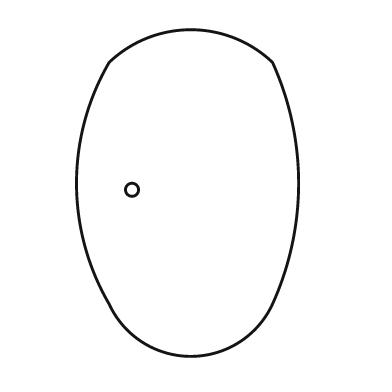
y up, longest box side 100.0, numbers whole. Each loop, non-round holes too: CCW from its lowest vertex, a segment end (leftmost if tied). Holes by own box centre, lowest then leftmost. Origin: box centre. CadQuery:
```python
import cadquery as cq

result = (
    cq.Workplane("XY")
    .moveTo(-24.0, -34.0)
    .threePointArc((1.0, -50.0), (26.0, -34.0))
    .threePointArc((34.0, 3.0), (26.0, 40.0))
    .threePointArc((1.0, 50.0), (-24.0, 40.0))
    .threePointArc((-34.0, 3.0), (-24.0, -34.0))
    .close()
    .moveTo(-17.0, 1.0)
    .circle(2.0)
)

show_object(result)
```